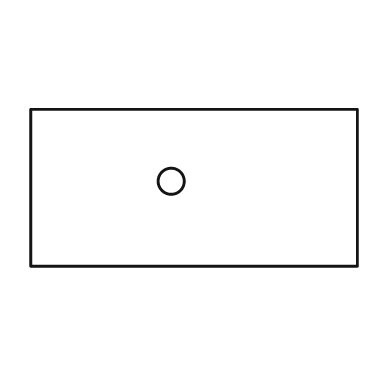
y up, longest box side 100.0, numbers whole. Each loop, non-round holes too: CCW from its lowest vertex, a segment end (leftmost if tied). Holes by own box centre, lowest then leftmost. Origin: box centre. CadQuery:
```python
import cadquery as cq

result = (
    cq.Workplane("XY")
    .moveTo(-50.0, -24.0)
    .lineTo(50.0, -24.0)
    .lineTo(50.0, 24.0)
    .lineTo(-50.0, 24.0)
    .close()
    .moveTo(-7.0, 2.0)
    .circle(4.0)
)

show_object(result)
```